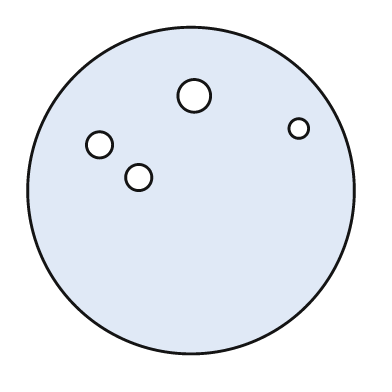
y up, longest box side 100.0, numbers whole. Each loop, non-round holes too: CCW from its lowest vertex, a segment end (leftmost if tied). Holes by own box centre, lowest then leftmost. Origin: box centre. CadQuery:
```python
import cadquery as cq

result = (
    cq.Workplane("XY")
    .moveTo(0.0, 0.0)
    .circle(50.0)
    .moveTo(-16.0, 4.0)
    .circle(4.0)
    .moveTo(-28.0, 14.0)
    .circle(4.0)
    .moveTo(33.0, 19.0)
    .circle(3.0)
    .moveTo(1.0, 29.0)
    .circle(5.0)
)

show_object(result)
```